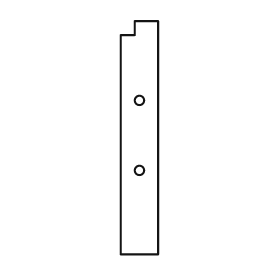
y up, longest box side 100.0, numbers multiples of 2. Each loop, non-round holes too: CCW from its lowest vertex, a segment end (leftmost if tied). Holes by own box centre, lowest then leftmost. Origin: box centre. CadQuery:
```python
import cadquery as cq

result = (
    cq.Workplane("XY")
    .moveTo(-8.0, -50.0)
    .lineTo(8.0, -50.0)
    .lineTo(8.0, 50.0)
    .lineTo(-2.0, 50.0)
    .lineTo(-2.0, 44.0)
    .lineTo(-8.0, 44.0)
    .close()
    .moveTo(0.0, -14.0)
    .circle(2.0)
    .moveTo(0.0, 16.0)
    .circle(2.0)
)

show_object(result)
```